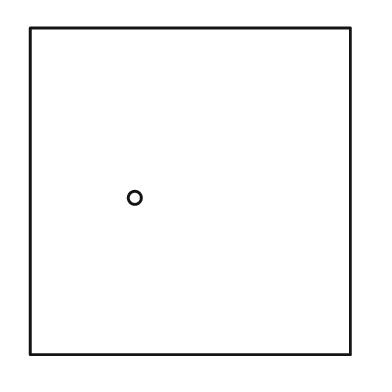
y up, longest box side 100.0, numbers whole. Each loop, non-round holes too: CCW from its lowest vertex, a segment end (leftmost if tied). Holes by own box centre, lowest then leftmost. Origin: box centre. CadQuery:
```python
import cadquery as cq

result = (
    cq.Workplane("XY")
    .moveTo(-49.0, -50.0)
    .lineTo(49.0, -50.0)
    .lineTo(49.0, 50.0)
    .lineTo(-49.0, 50.0)
    .close()
    .moveTo(-17.0, -2.0)
    .circle(2.0)
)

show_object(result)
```